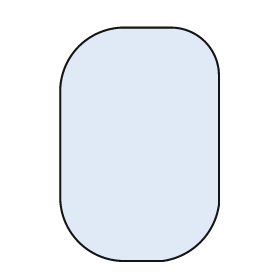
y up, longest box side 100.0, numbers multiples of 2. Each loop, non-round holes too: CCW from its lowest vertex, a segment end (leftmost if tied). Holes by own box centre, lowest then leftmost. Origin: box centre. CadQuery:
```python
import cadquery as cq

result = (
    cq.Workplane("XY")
    .moveTo(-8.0, -50.0)
    .lineTo(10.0, -50.0)
    .threePointArc((26.0, -42.0), (34.0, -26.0))
    .lineTo(34.0, 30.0)
    .threePointArc((28.0, 44.0), (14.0, 50.0))
    .lineTo(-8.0, 50.0)
    .threePointArc((-26.0, 42.0), (-34.0, 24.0))
    .lineTo(-34.0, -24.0)
    .threePointArc((-26.0, -42.0), (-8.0, -50.0))
    .close()
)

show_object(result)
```